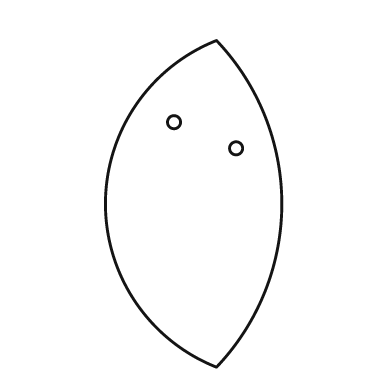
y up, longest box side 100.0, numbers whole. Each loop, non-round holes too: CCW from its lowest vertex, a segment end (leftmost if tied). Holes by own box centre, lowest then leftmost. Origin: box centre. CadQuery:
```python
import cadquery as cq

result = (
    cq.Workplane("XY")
    .moveTo(7.0, -50.0)
    .threePointArc((27.0, 0.0), (7.0, 50.0))
    .threePointArc((-27.0, 0.0), (7.0, -50.0))
    .close()
    .moveTo(13.0, 17.0)
    .circle(2.0)
    .moveTo(-6.0, 25.0)
    .circle(2.0)
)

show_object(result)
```